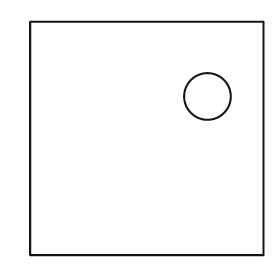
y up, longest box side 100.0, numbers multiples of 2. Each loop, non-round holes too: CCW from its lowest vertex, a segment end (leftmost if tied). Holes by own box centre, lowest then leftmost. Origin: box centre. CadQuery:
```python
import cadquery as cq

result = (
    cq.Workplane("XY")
    .moveTo(-50.0, -50.0)
    .lineTo(50.0, -50.0)
    .lineTo(50.0, 50.0)
    .lineTo(-50.0, 50.0)
    .close()
    .moveTo(26.0, 18.0)
    .circle(10.0)
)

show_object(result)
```